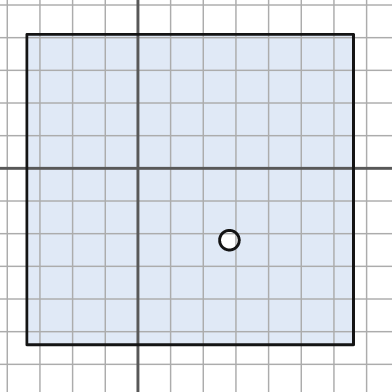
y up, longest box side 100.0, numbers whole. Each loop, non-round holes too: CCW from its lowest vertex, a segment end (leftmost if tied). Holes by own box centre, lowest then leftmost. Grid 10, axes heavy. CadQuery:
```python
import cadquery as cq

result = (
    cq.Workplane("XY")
    .moveTo(-34.0, -54.0)
    .lineTo(66.0, -54.0)
    .lineTo(66.0, 41.0)
    .lineTo(-34.0, 41.0)
    .close()
    .moveTo(28.0, -22.0)
    .circle(3.0)
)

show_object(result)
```